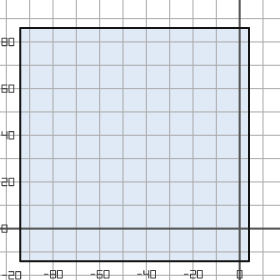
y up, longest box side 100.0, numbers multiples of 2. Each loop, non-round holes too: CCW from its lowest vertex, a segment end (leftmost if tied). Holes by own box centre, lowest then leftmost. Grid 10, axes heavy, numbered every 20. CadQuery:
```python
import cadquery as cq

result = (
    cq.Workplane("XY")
    .moveTo(-94.0, -14.0)
    .lineTo(4.0, -14.0)
    .lineTo(4.0, 86.0)
    .lineTo(-94.0, 86.0)
    .close()
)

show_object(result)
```